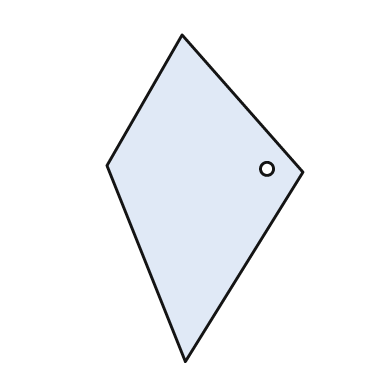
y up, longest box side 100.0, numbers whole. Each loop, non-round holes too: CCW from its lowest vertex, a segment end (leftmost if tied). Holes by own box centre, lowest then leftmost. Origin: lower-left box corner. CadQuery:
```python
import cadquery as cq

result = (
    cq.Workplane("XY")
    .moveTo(24.0, 0.0)
    .lineTo(60.0, 58.0)
    .lineTo(23.0, 100.0)
    .lineTo(0.0, 60.0)
    .close()
    .moveTo(49.0, 59.0)
    .circle(2.0)
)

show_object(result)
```